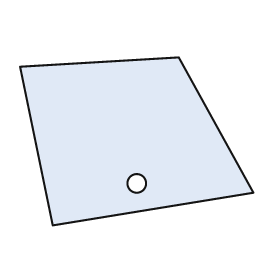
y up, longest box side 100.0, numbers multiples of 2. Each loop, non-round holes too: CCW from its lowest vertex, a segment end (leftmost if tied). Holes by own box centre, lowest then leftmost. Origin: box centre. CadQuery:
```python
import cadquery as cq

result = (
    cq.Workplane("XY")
    .moveTo(-36.0, -36.0)
    .lineTo(50.0, -22.0)
    .lineTo(18.0, 36.0)
    .lineTo(-50.0, 32.0)
    .close()
    .moveTo(0.0, -18.0)
    .circle(4.0)
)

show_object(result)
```